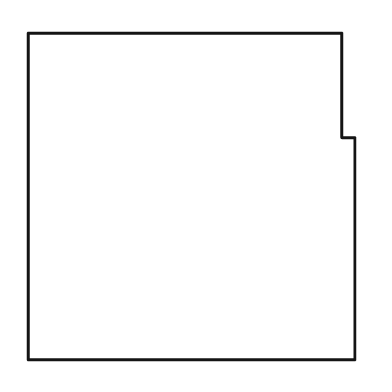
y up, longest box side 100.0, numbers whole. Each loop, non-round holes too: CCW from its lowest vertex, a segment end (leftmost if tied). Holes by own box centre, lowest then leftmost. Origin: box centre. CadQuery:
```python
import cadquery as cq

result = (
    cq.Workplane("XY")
    .moveTo(-50.0, -50.0)
    .lineTo(50.0, -50.0)
    .lineTo(50.0, 18.0)
    .lineTo(46.0, 18.0)
    .lineTo(46.0, 50.0)
    .lineTo(-50.0, 50.0)
    .close()
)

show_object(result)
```